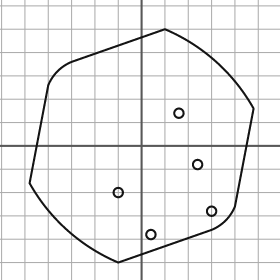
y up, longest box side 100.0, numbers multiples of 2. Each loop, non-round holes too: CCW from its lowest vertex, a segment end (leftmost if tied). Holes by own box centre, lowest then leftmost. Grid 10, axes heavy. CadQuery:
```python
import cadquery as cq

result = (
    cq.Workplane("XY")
    .moveTo(-10.0, -50.0)
    .lineTo(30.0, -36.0)
    .threePointArc((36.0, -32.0), (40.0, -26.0))
    .lineTo(48.0, 16.0)
    .threePointArc((32.0, 36.0), (10.0, 50.0))
    .lineTo(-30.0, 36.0)
    .threePointArc((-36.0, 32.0), (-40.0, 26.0))
    .lineTo(-48.0, -16.0)
    .threePointArc((-32.0, -36.0), (-10.0, -50.0))
    .close()
    .moveTo(4.0, -38.0)
    .circle(2.0)
    .moveTo(30.0, -28.0)
    .circle(2.0)
    .moveTo(-10.0, -20.0)
    .circle(2.0)
    .moveTo(24.0, -8.0)
    .circle(2.0)
    .moveTo(16.0, 14.0)
    .circle(2.0)
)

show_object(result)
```